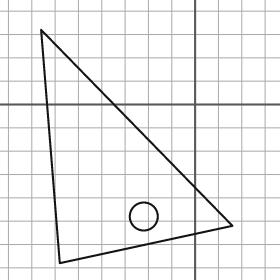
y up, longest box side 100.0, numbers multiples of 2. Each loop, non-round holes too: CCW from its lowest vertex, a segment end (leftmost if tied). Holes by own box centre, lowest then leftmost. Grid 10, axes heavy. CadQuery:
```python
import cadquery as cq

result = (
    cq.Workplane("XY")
    .moveTo(-58.0, -68.0)
    .lineTo(16.0, -52.0)
    .lineTo(-66.0, 32.0)
    .close()
    .moveTo(-22.0, -48.0)
    .circle(6.0)
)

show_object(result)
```